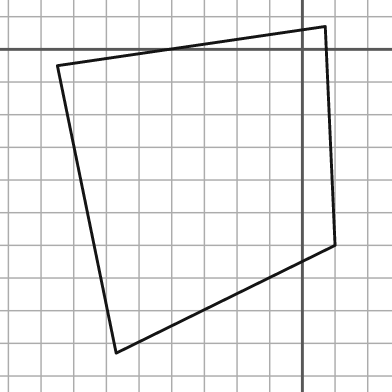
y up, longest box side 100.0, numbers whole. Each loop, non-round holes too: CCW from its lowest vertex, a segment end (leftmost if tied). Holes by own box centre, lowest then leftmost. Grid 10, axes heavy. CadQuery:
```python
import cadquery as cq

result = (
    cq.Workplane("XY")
    .moveTo(-57.0, -93.0)
    .lineTo(10.0, -60.0)
    .lineTo(7.0, 7.0)
    .lineTo(-75.0, -5.0)
    .close()
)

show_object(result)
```